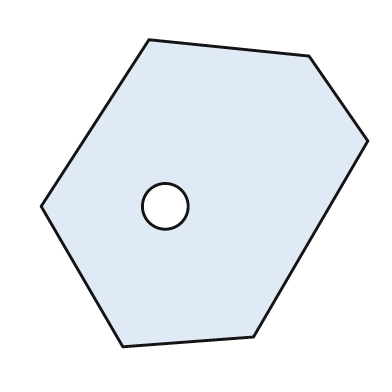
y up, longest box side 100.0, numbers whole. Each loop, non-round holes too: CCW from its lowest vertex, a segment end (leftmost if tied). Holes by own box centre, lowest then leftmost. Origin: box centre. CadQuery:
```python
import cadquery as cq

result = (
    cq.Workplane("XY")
    .moveTo(-25.0, -47.0)
    .lineTo(15.0, -44.0)
    .lineTo(50.0, 16.0)
    .lineTo(32.0, 42.0)
    .lineTo(-17.0, 47.0)
    .lineTo(-50.0, -4.0)
    .close()
    .moveTo(-12.0, -4.0)
    .circle(7.0)
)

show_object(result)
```